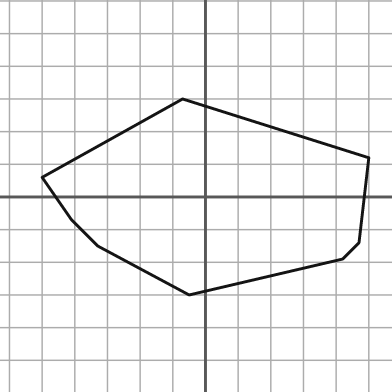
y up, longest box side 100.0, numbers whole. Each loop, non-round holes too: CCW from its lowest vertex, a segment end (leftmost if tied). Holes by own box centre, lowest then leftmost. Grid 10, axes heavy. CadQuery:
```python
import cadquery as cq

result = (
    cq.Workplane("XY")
    .moveTo(-5.0, -30.0)
    .lineTo(42.0, -19.0)
    .lineTo(47.0, -14.0)
    .lineTo(50.0, 12.0)
    .lineTo(-7.0, 30.0)
    .lineTo(-50.0, 6.0)
    .lineTo(-41.0, -7.0)
    .lineTo(-33.0, -15.0)
    .close()
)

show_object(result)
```